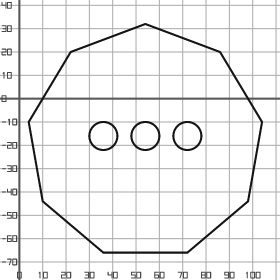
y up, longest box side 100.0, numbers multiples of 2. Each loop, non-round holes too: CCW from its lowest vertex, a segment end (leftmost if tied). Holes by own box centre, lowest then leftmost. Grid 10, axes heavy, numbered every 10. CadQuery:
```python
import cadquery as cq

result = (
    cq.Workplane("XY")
    .moveTo(36.0, -66.0)
    .lineTo(72.0, -66.0)
    .lineTo(98.0, -44.0)
    .lineTo(104.0, -10.0)
    .lineTo(86.0, 20.0)
    .lineTo(54.0, 32.0)
    .lineTo(22.0, 20.0)
    .lineTo(4.0, -10.0)
    .lineTo(10.0, -44.0)
    .close()
    .moveTo(36.0, -16.0)
    .circle(6.0)
    .moveTo(54.0, -16.0)
    .circle(6.0)
    .moveTo(72.0, -16.0)
    .circle(6.0)
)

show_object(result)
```